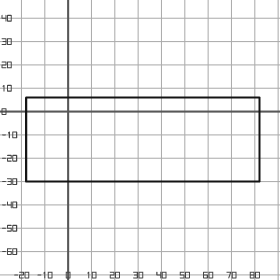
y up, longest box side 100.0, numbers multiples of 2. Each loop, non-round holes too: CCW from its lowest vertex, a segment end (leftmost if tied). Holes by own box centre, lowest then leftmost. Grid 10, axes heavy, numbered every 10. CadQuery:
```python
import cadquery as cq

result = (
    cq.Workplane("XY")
    .moveTo(-18.0, -30.0)
    .lineTo(82.0, -30.0)
    .lineTo(82.0, 6.0)
    .lineTo(-18.0, 6.0)
    .close()
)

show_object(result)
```